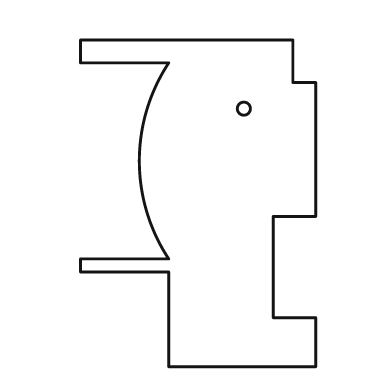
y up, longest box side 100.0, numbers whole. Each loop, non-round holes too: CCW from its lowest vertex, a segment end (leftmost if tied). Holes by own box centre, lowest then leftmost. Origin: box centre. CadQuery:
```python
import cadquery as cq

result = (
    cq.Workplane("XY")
    .moveTo(-9.0, -50.0)
    .lineTo(36.0, -50.0)
    .lineTo(36.0, -35.0)
    .lineTo(23.0, -35.0)
    .lineTo(23.0, -4.0)
    .lineTo(36.0, -4.0)
    .lineTo(36.0, 37.0)
    .lineTo(29.0, 37.0)
    .lineTo(29.0, 50.0)
    .lineTo(-36.0, 50.0)
    .lineTo(-36.0, 43.0)
    .lineTo(-9.0, 43.0)
    .threePointArc((-18.0, 13.0), (-9.0, -17.0))
    .lineTo(-36.0, -17.0)
    .lineTo(-36.0, -21.0)
    .lineTo(-9.0, -21.0)
    .close()
    .moveTo(14.0, 29.0)
    .circle(2.0)
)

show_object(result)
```